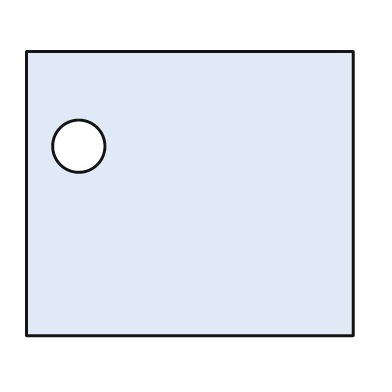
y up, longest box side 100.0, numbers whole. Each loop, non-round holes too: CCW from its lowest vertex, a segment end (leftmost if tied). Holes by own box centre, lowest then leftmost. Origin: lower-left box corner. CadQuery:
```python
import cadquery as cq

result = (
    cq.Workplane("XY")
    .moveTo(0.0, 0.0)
    .lineTo(100.0, 0.0)
    .lineTo(100.0, 87.0)
    .lineTo(0.0, 87.0)
    .close()
    .moveTo(16.0, 58.0)
    .circle(8.0)
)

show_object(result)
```